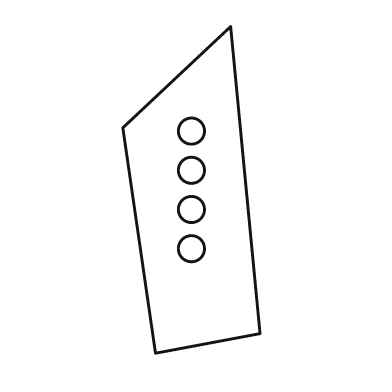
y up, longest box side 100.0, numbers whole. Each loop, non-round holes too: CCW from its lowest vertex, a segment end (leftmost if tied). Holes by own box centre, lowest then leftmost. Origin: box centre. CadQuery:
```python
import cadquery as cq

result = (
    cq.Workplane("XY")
    .moveTo(-11.0, -50.0)
    .lineTo(21.0, -44.0)
    .lineTo(12.0, 50.0)
    .lineTo(-21.0, 19.0)
    .close()
    .moveTo(0.0, -18.0)
    .circle(4.0)
    .moveTo(0.0, -6.0)
    .circle(4.0)
    .moveTo(0.0, 6.0)
    .circle(4.0)
    .moveTo(0.0, 18.0)
    .circle(4.0)
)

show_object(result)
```